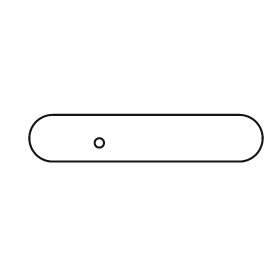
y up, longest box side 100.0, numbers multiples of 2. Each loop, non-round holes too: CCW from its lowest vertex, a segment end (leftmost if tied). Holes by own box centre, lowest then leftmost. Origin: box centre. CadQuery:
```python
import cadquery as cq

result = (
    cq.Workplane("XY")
    .moveTo(-40.0, -10.0)
    .lineTo(40.0, -10.0)
    .threePointArc((50.0, 0.0), (40.0, 10.0))
    .lineTo(-40.0, 10.0)
    .threePointArc((-50.0, 0.0), (-40.0, -10.0))
    .close()
    .moveTo(-20.0, -2.0)
    .circle(2.0)
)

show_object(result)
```